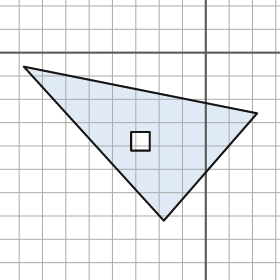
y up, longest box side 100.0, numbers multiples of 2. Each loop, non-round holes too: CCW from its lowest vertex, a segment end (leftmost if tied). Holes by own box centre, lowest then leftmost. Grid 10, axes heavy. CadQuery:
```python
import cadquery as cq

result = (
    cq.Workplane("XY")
    .moveTo(-18.0, -72.0)
    .lineTo(22.0, -26.0)
    .lineTo(-78.0, -6.0)
    .close()
    .moveTo(-32.0, -42.0)
    .lineTo(-24.0, -42.0)
    .lineTo(-24.0, -34.0)
    .lineTo(-32.0, -34.0)
    .close()
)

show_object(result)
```